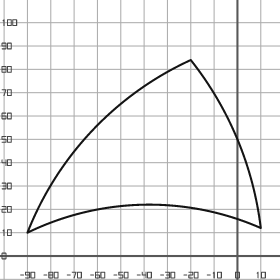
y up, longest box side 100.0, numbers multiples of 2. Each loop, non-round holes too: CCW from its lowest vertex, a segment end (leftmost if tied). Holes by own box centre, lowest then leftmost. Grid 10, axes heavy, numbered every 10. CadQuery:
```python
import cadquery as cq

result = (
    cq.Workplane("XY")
    .moveTo(-90.0, 10.0)
    .threePointArc((-40.0, 22.0), (10.0, 12.0))
    .threePointArc((0.0, 50.0), (-20.0, 84.0))
    .threePointArc((-62.0, 54.0), (-90.0, 10.0))
    .close()
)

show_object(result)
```